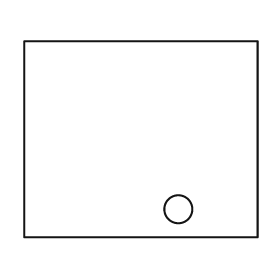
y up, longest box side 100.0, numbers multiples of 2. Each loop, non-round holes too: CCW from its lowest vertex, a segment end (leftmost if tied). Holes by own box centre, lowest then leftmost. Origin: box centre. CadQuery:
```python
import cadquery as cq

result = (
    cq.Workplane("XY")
    .moveTo(-50.0, -42.0)
    .lineTo(50.0, -42.0)
    .lineTo(50.0, 42.0)
    .lineTo(-50.0, 42.0)
    .close()
    .moveTo(16.0, -30.0)
    .circle(6.0)
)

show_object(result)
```